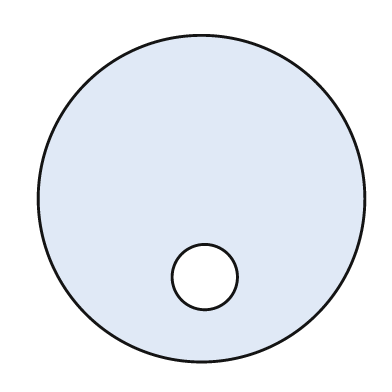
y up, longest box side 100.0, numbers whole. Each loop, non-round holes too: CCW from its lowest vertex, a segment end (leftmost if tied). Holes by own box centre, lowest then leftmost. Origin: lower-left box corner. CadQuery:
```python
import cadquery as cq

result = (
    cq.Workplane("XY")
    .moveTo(50.0, 50.0)
    .circle(50.0)
    .moveTo(51.0, 26.0)
    .circle(10.0)
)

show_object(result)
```